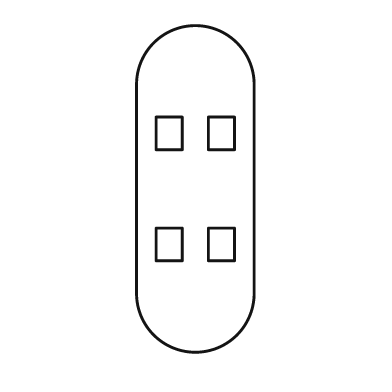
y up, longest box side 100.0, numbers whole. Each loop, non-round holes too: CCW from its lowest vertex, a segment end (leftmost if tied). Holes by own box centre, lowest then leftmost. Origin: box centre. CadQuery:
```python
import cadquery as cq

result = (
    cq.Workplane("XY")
    .moveTo(-18.0, -32.0)
    .threePointArc((0.0, -50.0), (18.0, -32.0))
    .lineTo(18.0, 32.0)
    .threePointArc((0.0, 50.0), (-18.0, 32.0))
    .close()
    .moveTo(-12.0, -22.0)
    .lineTo(-4.0, -22.0)
    .lineTo(-4.0, -12.0)
    .lineTo(-12.0, -12.0)
    .close()
    .moveTo(4.0, -22.0)
    .lineTo(12.0, -22.0)
    .lineTo(12.0, -12.0)
    .lineTo(4.0, -12.0)
    .close()
    .moveTo(-12.0, 12.0)
    .lineTo(-4.0, 12.0)
    .lineTo(-4.0, 22.0)
    .lineTo(-12.0, 22.0)
    .close()
    .moveTo(4.0, 12.0)
    .lineTo(12.0, 12.0)
    .lineTo(12.0, 22.0)
    .lineTo(4.0, 22.0)
    .close()
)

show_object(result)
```